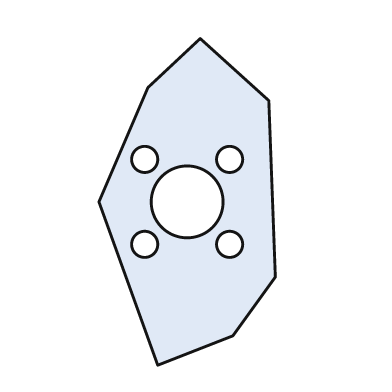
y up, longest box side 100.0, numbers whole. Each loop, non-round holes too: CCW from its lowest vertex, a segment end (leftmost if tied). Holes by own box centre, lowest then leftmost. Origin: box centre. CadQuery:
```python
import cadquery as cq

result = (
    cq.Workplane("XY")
    .moveTo(-9.0, -50.0)
    .lineTo(14.0, -41.0)
    .lineTo(27.0, -23.0)
    .lineTo(25.0, 31.0)
    .lineTo(4.0, 50.0)
    .lineTo(-12.0, 35.0)
    .lineTo(-27.0, 0.0)
    .close()
    .moveTo(-13.0, -13.0)
    .circle(4.0)
    .moveTo(13.0, -13.0)
    .circle(4.0)
    .moveTo(0.0, 0.0)
    .circle(11.0)
    .moveTo(-13.0, 13.0)
    .circle(4.0)
    .moveTo(13.0, 13.0)
    .circle(4.0)
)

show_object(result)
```